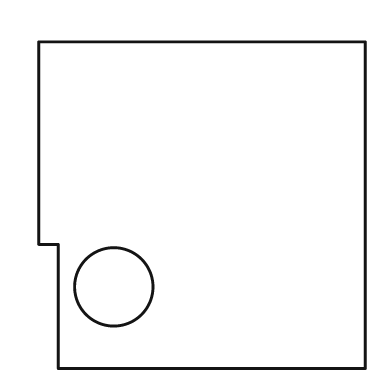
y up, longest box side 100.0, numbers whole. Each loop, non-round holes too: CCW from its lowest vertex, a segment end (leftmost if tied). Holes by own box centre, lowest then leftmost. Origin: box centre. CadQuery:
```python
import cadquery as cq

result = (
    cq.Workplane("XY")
    .moveTo(-44.0, -50.0)
    .lineTo(50.0, -50.0)
    .lineTo(50.0, 50.0)
    .lineTo(-50.0, 50.0)
    .lineTo(-50.0, -12.0)
    .lineTo(-44.0, -12.0)
    .close()
    .moveTo(-27.0, -25.0)
    .circle(12.0)
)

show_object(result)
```